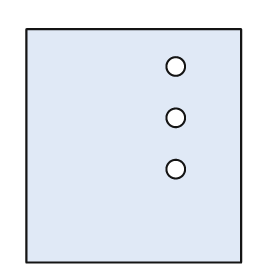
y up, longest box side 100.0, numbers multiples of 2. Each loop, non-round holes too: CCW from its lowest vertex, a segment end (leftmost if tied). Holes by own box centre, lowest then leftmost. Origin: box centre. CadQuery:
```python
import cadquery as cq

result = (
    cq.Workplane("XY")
    .moveTo(-46.0, -50.0)
    .lineTo(46.0, -50.0)
    .lineTo(46.0, 50.0)
    .lineTo(-46.0, 50.0)
    .close()
    .moveTo(18.0, -10.0)
    .circle(4.0)
    .moveTo(18.0, 12.0)
    .circle(4.0)
    .moveTo(18.0, 34.0)
    .circle(4.0)
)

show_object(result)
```